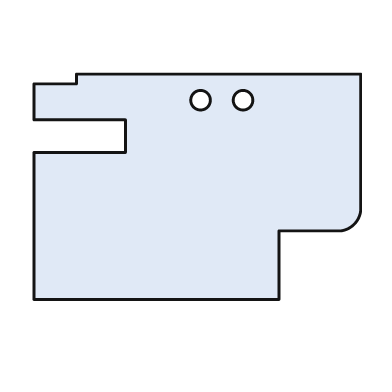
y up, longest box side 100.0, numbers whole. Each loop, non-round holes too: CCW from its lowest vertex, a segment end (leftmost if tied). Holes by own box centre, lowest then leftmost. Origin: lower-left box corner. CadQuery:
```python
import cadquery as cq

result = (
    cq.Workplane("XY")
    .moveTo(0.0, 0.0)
    .lineTo(75.0, 0.0)
    .lineTo(75.0, 21.0)
    .lineTo(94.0, 21.0)
    .threePointArc((98.0, 23.0), (100.0, 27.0))
    .lineTo(100.0, 69.0)
    .lineTo(13.0, 69.0)
    .lineTo(13.0, 66.0)
    .lineTo(0.0, 66.0)
    .lineTo(0.0, 55.0)
    .lineTo(28.0, 55.0)
    .lineTo(28.0, 45.0)
    .lineTo(0.0, 45.0)
    .close()
    .moveTo(51.0, 61.0)
    .circle(3.0)
    .moveTo(64.0, 61.0)
    .circle(3.0)
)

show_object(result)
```